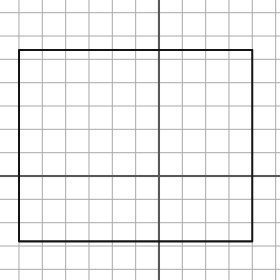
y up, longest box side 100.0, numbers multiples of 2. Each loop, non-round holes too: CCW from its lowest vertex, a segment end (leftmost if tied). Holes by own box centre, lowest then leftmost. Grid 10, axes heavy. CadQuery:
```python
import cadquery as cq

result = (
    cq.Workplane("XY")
    .moveTo(-60.0, -28.0)
    .lineTo(40.0, -28.0)
    .lineTo(40.0, 54.0)
    .lineTo(-60.0, 54.0)
    .close()
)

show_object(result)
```